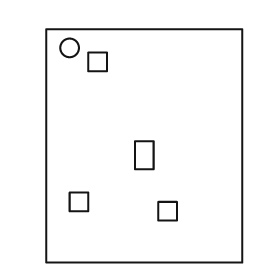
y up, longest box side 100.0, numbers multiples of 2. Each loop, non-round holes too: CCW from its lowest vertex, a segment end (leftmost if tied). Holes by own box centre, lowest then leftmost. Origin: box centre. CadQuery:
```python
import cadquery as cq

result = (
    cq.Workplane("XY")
    .moveTo(-42.0, -50.0)
    .lineTo(42.0, -50.0)
    .lineTo(42.0, 50.0)
    .lineTo(-42.0, 50.0)
    .close()
    .moveTo(6.0, -32.0)
    .lineTo(14.0, -32.0)
    .lineTo(14.0, -24.0)
    .lineTo(6.0, -24.0)
    .close()
    .moveTo(-32.0, -28.0)
    .lineTo(-24.0, -28.0)
    .lineTo(-24.0, -20.0)
    .lineTo(-32.0, -20.0)
    .close()
    .moveTo(-4.0, -10.0)
    .lineTo(4.0, -10.0)
    .lineTo(4.0, 2.0)
    .lineTo(-4.0, 2.0)
    .close()
    .moveTo(-24.0, 32.0)
    .lineTo(-16.0, 32.0)
    .lineTo(-16.0, 40.0)
    .lineTo(-24.0, 40.0)
    .close()
    .moveTo(-32.0, 42.0)
    .circle(4.0)
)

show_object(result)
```